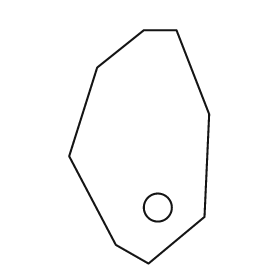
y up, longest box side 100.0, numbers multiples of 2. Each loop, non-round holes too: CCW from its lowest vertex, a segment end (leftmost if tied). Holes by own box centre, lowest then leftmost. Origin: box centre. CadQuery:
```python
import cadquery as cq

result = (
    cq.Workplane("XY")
    .moveTo(4.0, -50.0)
    .lineTo(28.0, -30.0)
    .lineTo(30.0, 14.0)
    .lineTo(16.0, 50.0)
    .lineTo(2.0, 50.0)
    .lineTo(-18.0, 34.0)
    .lineTo(-30.0, -4.0)
    .lineTo(-10.0, -42.0)
    .close()
    .moveTo(8.0, -26.0)
    .circle(6.0)
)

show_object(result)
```